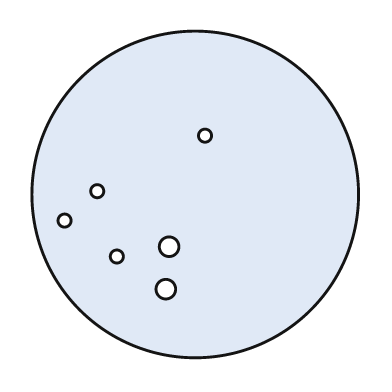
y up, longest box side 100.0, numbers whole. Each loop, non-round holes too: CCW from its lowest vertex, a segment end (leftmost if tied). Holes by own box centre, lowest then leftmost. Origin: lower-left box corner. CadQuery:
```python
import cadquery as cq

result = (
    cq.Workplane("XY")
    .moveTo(50.0, 50.0)
    .circle(50.0)
    .moveTo(41.0, 21.0)
    .circle(3.0)
    .moveTo(26.0, 31.0)
    .circle(2.0)
    .moveTo(42.0, 34.0)
    .circle(3.0)
    .moveTo(10.0, 42.0)
    .circle(2.0)
    .moveTo(20.0, 51.0)
    .circle(2.0)
    .moveTo(53.0, 68.0)
    .circle(2.0)
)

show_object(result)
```